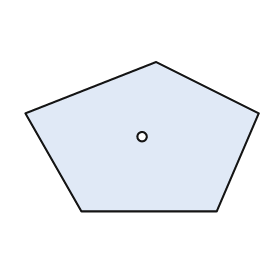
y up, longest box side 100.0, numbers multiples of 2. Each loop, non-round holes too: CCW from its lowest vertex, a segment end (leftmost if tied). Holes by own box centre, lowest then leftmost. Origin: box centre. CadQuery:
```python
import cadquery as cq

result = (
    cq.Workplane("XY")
    .moveTo(-26.0, -32.0)
    .lineTo(32.0, -32.0)
    .lineTo(50.0, 10.0)
    .lineTo(6.0, 32.0)
    .lineTo(-50.0, 10.0)
    .close()
    .moveTo(0.0, 0.0)
    .circle(2.0)
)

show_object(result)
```